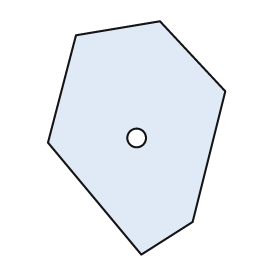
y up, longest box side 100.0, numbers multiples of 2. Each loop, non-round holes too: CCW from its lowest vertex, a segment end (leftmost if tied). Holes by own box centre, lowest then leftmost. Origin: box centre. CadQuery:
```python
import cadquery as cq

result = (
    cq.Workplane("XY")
    .moveTo(2.0, -50.0)
    .lineTo(24.0, -36.0)
    .lineTo(38.0, 20.0)
    .lineTo(10.0, 50.0)
    .lineTo(-26.0, 44.0)
    .lineTo(-38.0, -2.0)
    .close()
    .moveTo(0.0, 0.0)
    .circle(4.0)
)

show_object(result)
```